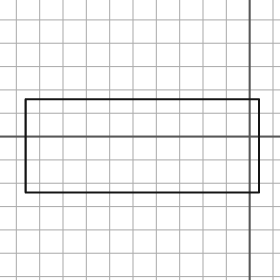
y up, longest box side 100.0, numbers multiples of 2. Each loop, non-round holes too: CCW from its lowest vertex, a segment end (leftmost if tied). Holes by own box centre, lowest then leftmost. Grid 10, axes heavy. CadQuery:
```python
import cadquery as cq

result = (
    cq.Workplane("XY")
    .moveTo(-96.0, -24.0)
    .lineTo(4.0, -24.0)
    .lineTo(4.0, 16.0)
    .lineTo(-96.0, 16.0)
    .close()
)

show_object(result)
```